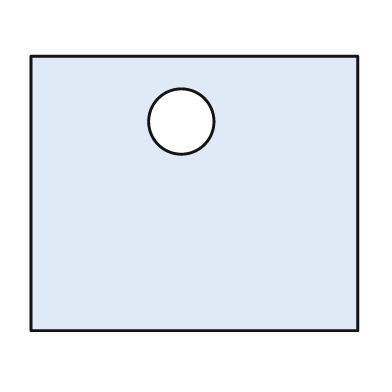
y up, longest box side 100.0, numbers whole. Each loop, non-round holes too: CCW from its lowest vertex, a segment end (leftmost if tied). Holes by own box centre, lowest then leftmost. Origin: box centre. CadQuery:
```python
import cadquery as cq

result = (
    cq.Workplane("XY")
    .moveTo(-50.0, -42.0)
    .lineTo(50.0, -42.0)
    .lineTo(50.0, 42.0)
    .lineTo(-50.0, 42.0)
    .close()
    .moveTo(-4.0, 22.0)
    .circle(10.0)
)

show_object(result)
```